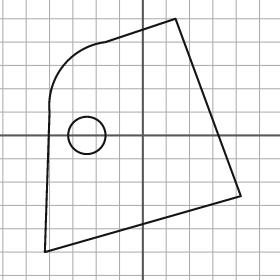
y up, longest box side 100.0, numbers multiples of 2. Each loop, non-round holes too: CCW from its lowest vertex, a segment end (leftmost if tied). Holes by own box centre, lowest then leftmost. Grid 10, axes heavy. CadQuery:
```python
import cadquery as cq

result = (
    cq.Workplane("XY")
    .moveTo(-42.0, -50.0)
    .lineTo(42.0, -26.0)
    .lineTo(14.0, 50.0)
    .lineTo(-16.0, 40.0)
    .threePointArc((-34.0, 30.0), (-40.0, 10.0))
    .close()
    .moveTo(-24.0, 0.0)
    .circle(8.0)
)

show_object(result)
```